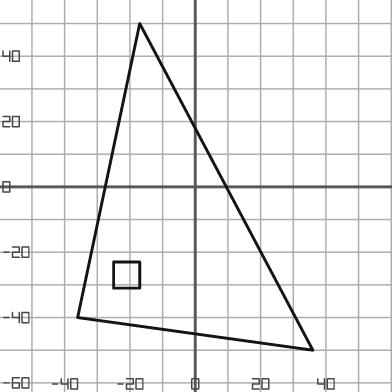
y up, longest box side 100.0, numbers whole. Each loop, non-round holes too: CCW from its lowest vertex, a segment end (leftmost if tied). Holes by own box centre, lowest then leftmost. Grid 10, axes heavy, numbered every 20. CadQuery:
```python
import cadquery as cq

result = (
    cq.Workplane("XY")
    .moveTo(36.0, -50.0)
    .lineTo(-17.0, 50.0)
    .lineTo(-36.0, -40.0)
    .close()
    .moveTo(-25.0, -31.0)
    .lineTo(-17.0, -31.0)
    .lineTo(-17.0, -23.0)
    .lineTo(-25.0, -23.0)
    .close()
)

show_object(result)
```